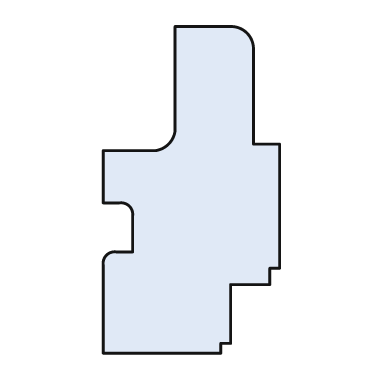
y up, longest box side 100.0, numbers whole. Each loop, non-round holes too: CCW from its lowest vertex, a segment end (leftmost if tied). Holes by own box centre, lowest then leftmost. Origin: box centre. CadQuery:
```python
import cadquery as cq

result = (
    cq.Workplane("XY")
    .moveTo(-27.0, -50.0)
    .lineTo(9.0, -50.0)
    .lineTo(9.0, -47.0)
    .lineTo(12.0, -47.0)
    .lineTo(12.0, -29.0)
    .lineTo(24.0, -29.0)
    .lineTo(24.0, -24.0)
    .lineTo(27.0, -24.0)
    .lineTo(27.0, 14.0)
    .lineTo(19.0, 14.0)
    .lineTo(19.0, 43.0)
    .threePointArc((17.0, 48.0), (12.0, 50.0))
    .lineTo(-5.0, 50.0)
    .lineTo(-5.0, 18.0)
    .threePointArc((-7.0, 14.0), (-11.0, 12.0))
    .lineTo(-27.0, 12.0)
    .lineTo(-27.0, -4.0)
    .lineTo(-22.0, -4.0)
    .threePointArc((-19.0, -5.0), (-18.0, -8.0))
    .lineTo(-18.0, -19.0)
    .lineTo(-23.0, -19.0)
    .threePointArc((-26.0, -20.0), (-27.0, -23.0))
    .close()
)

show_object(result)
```